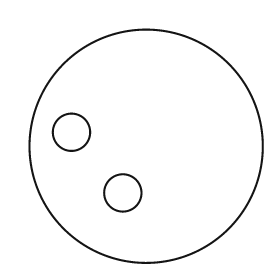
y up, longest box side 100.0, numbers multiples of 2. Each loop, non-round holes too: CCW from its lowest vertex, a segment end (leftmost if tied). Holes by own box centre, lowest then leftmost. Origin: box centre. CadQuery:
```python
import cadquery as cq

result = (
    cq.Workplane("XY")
    .moveTo(0.0, 0.0)
    .circle(50.0)
    .moveTo(-10.0, -20.0)
    .circle(8.0)
    .moveTo(-32.0, 6.0)
    .circle(8.0)
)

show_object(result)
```